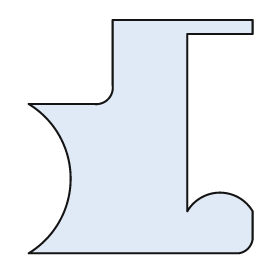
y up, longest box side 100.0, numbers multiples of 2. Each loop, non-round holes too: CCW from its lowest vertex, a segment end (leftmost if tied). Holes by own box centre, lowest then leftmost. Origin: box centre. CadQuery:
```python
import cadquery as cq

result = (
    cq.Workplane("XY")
    .moveTo(-48.0, -50.0)
    .lineTo(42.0, -50.0)
    .threePointArc((46.0, -48.0), (48.0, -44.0))
    .lineTo(48.0, -32.0)
    .threePointArc((34.0, -24.0), (20.0, -32.0))
    .lineTo(20.0, 44.0)
    .lineTo(48.0, 44.0)
    .lineTo(48.0, 50.0)
    .lineTo(-12.0, 50.0)
    .lineTo(-12.0, 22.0)
    .threePointArc((-14.0, 16.0), (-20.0, 14.0))
    .lineTo(-48.0, 14.0)
    .threePointArc((-30.0, -18.0), (-48.0, -50.0))
    .close()
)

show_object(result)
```